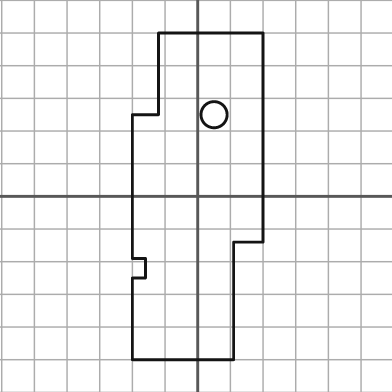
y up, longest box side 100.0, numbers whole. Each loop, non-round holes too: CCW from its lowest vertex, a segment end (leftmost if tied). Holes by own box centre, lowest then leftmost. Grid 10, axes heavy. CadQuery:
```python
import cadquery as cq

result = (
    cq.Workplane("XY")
    .moveTo(-20.0, -50.0)
    .lineTo(11.0, -50.0)
    .lineTo(11.0, -14.0)
    .lineTo(20.0, -14.0)
    .lineTo(20.0, 50.0)
    .lineTo(-12.0, 50.0)
    .lineTo(-12.0, 25.0)
    .lineTo(-20.0, 25.0)
    .lineTo(-20.0, -19.0)
    .lineTo(-16.0, -19.0)
    .lineTo(-16.0, -25.0)
    .lineTo(-20.0, -25.0)
    .close()
    .moveTo(5.0, 25.0)
    .circle(4.0)
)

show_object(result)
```